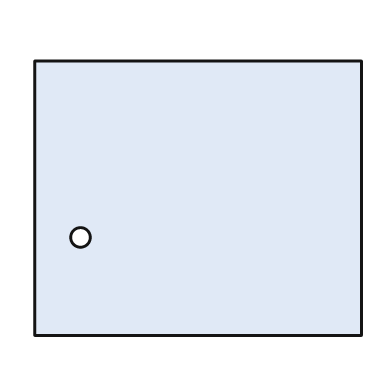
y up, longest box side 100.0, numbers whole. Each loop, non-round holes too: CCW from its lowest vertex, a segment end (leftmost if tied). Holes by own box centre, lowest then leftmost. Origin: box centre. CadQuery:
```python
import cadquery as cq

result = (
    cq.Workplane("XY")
    .moveTo(-50.0, -42.0)
    .lineTo(50.0, -42.0)
    .lineTo(50.0, 42.0)
    .lineTo(-50.0, 42.0)
    .close()
    .moveTo(-36.0, -12.0)
    .circle(3.0)
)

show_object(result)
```